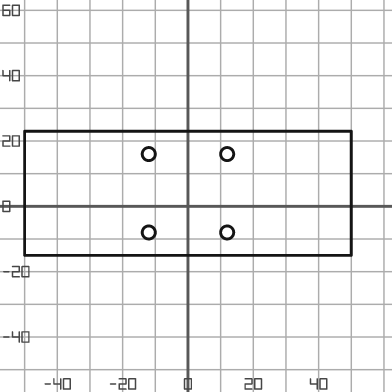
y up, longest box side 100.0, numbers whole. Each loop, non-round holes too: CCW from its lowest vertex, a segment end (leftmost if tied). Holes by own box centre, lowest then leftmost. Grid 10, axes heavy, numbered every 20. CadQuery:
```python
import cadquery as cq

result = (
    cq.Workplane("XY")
    .moveTo(-50.0, -15.0)
    .lineTo(50.0, -15.0)
    .lineTo(50.0, 23.0)
    .lineTo(-50.0, 23.0)
    .close()
    .moveTo(-12.0, -8.0)
    .circle(2.0)
    .moveTo(12.0, -8.0)
    .circle(2.0)
    .moveTo(-12.0, 16.0)
    .circle(2.0)
    .moveTo(12.0, 16.0)
    .circle(2.0)
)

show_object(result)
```